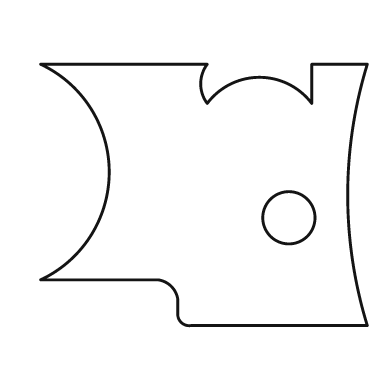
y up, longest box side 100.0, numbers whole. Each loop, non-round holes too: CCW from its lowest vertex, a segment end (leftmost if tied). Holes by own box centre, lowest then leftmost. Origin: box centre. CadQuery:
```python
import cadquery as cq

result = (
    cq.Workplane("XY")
    .moveTo(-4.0, -40.0)
    .lineTo(50.0, -40.0)
    .threePointArc((44.0, 0.0), (50.0, 40.0))
    .lineTo(33.0, 40.0)
    .lineTo(33.0, 28.0)
    .threePointArc((17.0, 36.0), (1.0, 28.0))
    .threePointArc((-1.0, 34.0), (1.0, 40.0))
    .lineTo(-50.0, 40.0)
    .threePointArc((-29.0, 7.0), (-50.0, -26.0))
    .lineTo(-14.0, -26.0)
    .threePointArc((-10.0, -28.0), (-8.0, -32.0))
    .lineTo(-8.0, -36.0)
    .threePointArc((-7.0, -39.0), (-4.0, -40.0))
    .close()
    .moveTo(26.0, -7.0)
    .circle(8.0)
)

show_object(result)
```